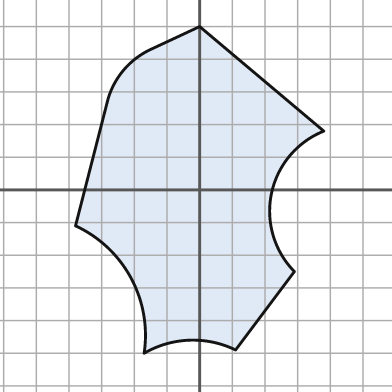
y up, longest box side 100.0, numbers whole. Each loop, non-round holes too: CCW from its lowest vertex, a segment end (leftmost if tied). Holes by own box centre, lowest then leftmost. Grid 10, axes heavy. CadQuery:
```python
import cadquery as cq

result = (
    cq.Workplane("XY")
    .moveTo(-17.0, -50.0)
    .threePointArc((-3.0, -46.0), (11.0, -49.0))
    .lineTo(29.0, -25.0)
    .threePointArc((22.0, -1.0), (38.0, 18.0))
    .lineTo(0.0, 50.0)
    .lineTo(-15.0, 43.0)
    .threePointArc((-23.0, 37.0), (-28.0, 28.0))
    .lineTo(-38.0, -11.0)
    .threePointArc((-21.0, -27.0), (-17.0, -50.0))
    .close()
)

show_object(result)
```